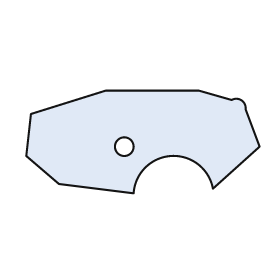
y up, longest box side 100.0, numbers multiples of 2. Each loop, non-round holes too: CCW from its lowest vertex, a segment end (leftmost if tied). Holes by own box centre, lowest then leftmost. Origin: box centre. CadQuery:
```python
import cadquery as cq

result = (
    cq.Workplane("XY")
    .moveTo(-4.0, -22.0)
    .threePointArc((12.0, -6.0), (30.0, -20.0))
    .lineTo(50.0, -2.0)
    .lineTo(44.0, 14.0)
    .threePointArc((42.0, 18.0), (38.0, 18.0))
    .lineTo(24.0, 22.0)
    .lineTo(-16.0, 22.0)
    .lineTo(-48.0, 12.0)
    .lineTo(-50.0, -6.0)
    .lineTo(-36.0, -18.0)
    .close()
    .moveTo(-8.0, -2.0)
    .circle(4.0)
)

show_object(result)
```